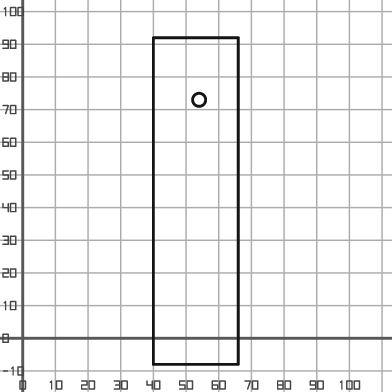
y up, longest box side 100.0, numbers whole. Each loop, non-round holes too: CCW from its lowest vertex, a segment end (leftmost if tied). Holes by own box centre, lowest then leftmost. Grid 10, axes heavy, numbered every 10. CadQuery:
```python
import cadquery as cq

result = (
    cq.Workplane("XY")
    .moveTo(40.0, -8.0)
    .lineTo(66.0, -8.0)
    .lineTo(66.0, 92.0)
    .lineTo(40.0, 92.0)
    .close()
    .moveTo(54.0, 73.0)
    .circle(2.0)
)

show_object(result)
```